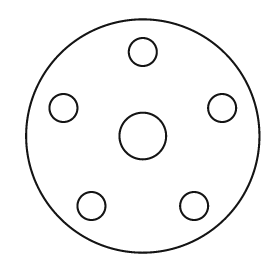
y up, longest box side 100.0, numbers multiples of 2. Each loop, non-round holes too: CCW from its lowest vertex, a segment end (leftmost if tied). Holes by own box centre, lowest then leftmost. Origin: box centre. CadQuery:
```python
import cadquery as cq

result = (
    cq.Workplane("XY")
    .moveTo(0.0, 0.0)
    .circle(50.0)
    .moveTo(-22.0, -30.0)
    .circle(6.0)
    .moveTo(22.0, -30.0)
    .circle(6.0)
    .moveTo(0.0, 0.0)
    .circle(10.0)
    .moveTo(-34.0, 12.0)
    .circle(6.0)
    .moveTo(34.0, 12.0)
    .circle(6.0)
    .moveTo(0.0, 36.0)
    .circle(6.0)
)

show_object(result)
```